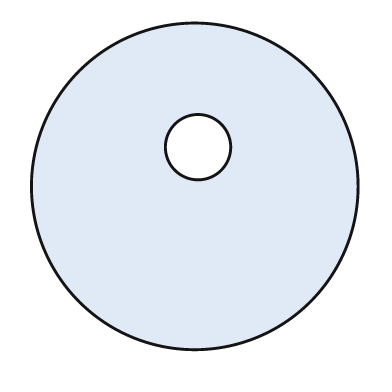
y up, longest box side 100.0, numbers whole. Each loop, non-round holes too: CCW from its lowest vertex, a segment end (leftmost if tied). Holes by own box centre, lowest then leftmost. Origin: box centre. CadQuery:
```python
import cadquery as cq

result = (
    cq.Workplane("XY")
    .moveTo(0.0, 0.0)
    .circle(50.0)
    .moveTo(1.0, 12.0)
    .circle(10.0)
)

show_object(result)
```